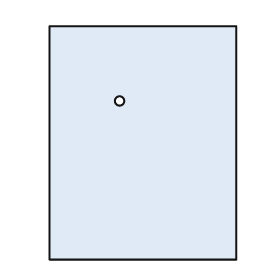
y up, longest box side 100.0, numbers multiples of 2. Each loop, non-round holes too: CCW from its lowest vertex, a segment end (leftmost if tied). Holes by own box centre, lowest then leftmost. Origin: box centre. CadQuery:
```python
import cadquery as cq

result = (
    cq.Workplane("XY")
    .moveTo(-40.0, -50.0)
    .lineTo(40.0, -50.0)
    .lineTo(40.0, 50.0)
    .lineTo(-40.0, 50.0)
    .close()
    .moveTo(-10.0, 18.0)
    .circle(2.0)
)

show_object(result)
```